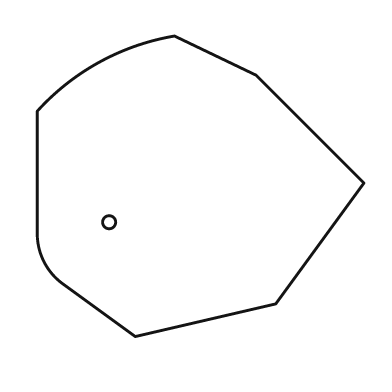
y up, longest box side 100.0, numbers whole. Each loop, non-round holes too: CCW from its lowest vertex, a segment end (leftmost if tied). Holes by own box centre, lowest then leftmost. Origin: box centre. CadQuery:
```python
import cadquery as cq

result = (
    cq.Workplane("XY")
    .moveTo(-20.0, -46.0)
    .lineTo(23.0, -36.0)
    .lineTo(50.0, 1.0)
    .lineTo(17.0, 34.0)
    .lineTo(-8.0, 46.0)
    .threePointArc((-31.0, 38.0), (-50.0, 23.0))
    .lineTo(-50.0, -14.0)
    .threePointArc((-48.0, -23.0), (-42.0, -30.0))
    .close()
    .moveTo(-28.0, -11.0)
    .circle(2.0)
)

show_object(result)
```